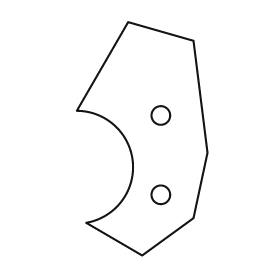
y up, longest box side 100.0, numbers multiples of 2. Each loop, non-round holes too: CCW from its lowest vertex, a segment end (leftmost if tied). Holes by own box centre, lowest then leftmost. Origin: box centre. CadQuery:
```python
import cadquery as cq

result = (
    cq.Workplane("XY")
    .moveTo(0.0, -50.0)
    .lineTo(22.0, -34.0)
    .lineTo(28.0, -6.0)
    .lineTo(22.0, 42.0)
    .lineTo(-6.0, 50.0)
    .lineTo(-28.0, 12.0)
    .threePointArc((-4.0, -10.0), (-24.0, -36.0))
    .close()
    .moveTo(8.0, -24.0)
    .circle(4.0)
    .moveTo(8.0, 10.0)
    .circle(4.0)
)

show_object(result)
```